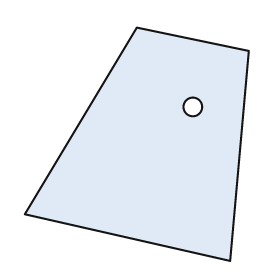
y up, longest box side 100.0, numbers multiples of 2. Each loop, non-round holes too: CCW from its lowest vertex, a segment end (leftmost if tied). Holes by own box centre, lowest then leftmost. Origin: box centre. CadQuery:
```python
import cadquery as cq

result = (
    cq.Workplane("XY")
    .moveTo(40.0, -50.0)
    .lineTo(48.0, 40.0)
    .lineTo(0.0, 50.0)
    .lineTo(-48.0, -30.0)
    .close()
    .moveTo(24.0, 16.0)
    .circle(4.0)
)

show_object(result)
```